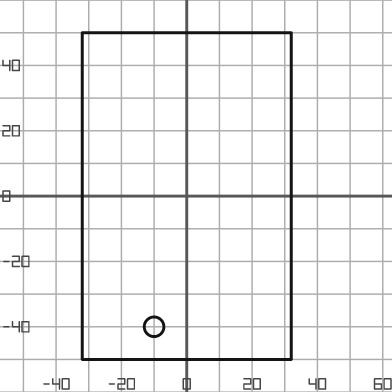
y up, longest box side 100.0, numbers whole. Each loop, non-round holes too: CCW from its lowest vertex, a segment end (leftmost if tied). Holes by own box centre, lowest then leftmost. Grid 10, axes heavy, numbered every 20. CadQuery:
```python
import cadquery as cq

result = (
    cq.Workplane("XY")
    .moveTo(-32.0, -50.0)
    .lineTo(32.0, -50.0)
    .lineTo(32.0, 50.0)
    .lineTo(-32.0, 50.0)
    .close()
    .moveTo(-10.0, -40.0)
    .circle(3.0)
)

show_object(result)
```